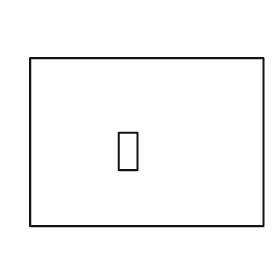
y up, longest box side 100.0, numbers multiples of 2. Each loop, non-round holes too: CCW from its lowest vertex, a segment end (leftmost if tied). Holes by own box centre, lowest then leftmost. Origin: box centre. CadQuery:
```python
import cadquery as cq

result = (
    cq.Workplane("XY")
    .moveTo(-50.0, -36.0)
    .lineTo(50.0, -36.0)
    .lineTo(50.0, 36.0)
    .lineTo(-50.0, 36.0)
    .close()
    .moveTo(-12.0, -12.0)
    .lineTo(-4.0, -12.0)
    .lineTo(-4.0, 4.0)
    .lineTo(-12.0, 4.0)
    .close()
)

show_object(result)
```